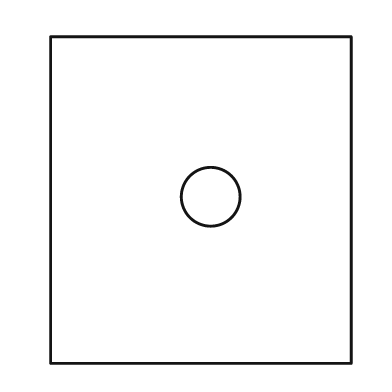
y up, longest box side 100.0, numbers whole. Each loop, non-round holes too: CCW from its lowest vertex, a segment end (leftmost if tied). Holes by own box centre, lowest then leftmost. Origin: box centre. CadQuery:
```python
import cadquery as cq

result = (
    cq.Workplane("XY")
    .moveTo(-46.0, -50.0)
    .lineTo(46.0, -50.0)
    .lineTo(46.0, 50.0)
    .lineTo(-46.0, 50.0)
    .close()
    .moveTo(3.0, 1.0)
    .circle(9.0)
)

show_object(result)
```